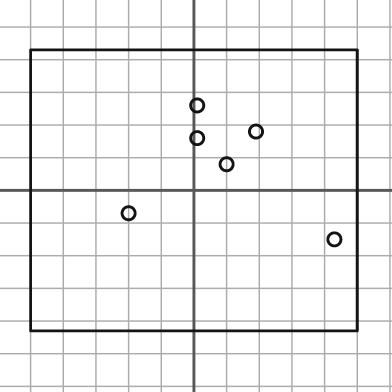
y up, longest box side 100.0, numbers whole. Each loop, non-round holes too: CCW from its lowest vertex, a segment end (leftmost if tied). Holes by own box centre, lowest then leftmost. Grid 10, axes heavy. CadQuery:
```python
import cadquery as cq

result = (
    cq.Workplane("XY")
    .moveTo(-50.0, -43.0)
    .lineTo(50.0, -43.0)
    .lineTo(50.0, 43.0)
    .lineTo(-50.0, 43.0)
    .close()
    .moveTo(43.0, -15.0)
    .circle(2.0)
    .moveTo(-20.0, -7.0)
    .circle(2.0)
    .moveTo(10.0, 8.0)
    .circle(2.0)
    .moveTo(1.0, 16.0)
    .circle(2.0)
    .moveTo(19.0, 18.0)
    .circle(2.0)
    .moveTo(1.0, 26.0)
    .circle(2.0)
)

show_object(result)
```